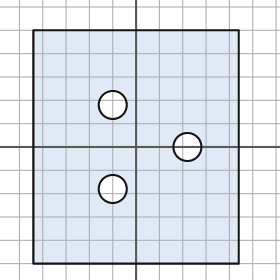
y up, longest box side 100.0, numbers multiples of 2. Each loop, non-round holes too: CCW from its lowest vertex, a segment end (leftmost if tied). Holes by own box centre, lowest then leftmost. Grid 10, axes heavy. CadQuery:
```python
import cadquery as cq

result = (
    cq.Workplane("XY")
    .moveTo(-44.0, -50.0)
    .lineTo(44.0, -50.0)
    .lineTo(44.0, 50.0)
    .lineTo(-44.0, 50.0)
    .close()
    .moveTo(-10.0, -18.0)
    .circle(6.0)
    .moveTo(22.0, 0.0)
    .circle(6.0)
    .moveTo(-10.0, 18.0)
    .circle(6.0)
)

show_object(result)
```